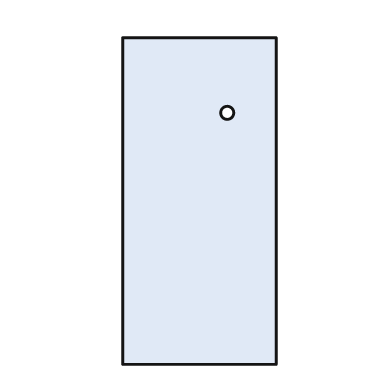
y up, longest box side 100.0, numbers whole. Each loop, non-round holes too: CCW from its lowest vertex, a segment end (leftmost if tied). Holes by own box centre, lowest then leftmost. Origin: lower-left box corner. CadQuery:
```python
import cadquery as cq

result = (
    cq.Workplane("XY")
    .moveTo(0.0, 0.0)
    .lineTo(47.0, 0.0)
    .lineTo(47.0, 100.0)
    .lineTo(0.0, 100.0)
    .close()
    .moveTo(32.0, 77.0)
    .circle(2.0)
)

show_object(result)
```